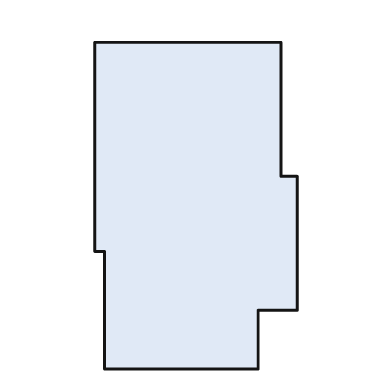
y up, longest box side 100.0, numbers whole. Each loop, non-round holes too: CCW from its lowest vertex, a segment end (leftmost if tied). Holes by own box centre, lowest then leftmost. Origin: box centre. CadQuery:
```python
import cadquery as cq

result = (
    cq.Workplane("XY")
    .moveTo(-28.0, -50.0)
    .lineTo(19.0, -50.0)
    .lineTo(19.0, -32.0)
    .lineTo(31.0, -32.0)
    .lineTo(31.0, 9.0)
    .lineTo(26.0, 9.0)
    .lineTo(26.0, 50.0)
    .lineTo(-31.0, 50.0)
    .lineTo(-31.0, -14.0)
    .lineTo(-28.0, -14.0)
    .close()
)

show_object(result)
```